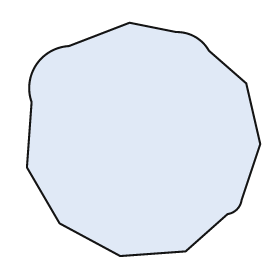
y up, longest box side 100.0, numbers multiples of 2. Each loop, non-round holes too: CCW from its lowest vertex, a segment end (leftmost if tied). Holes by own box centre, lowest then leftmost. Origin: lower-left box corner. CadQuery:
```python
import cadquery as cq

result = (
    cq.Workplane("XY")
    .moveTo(40.0, 0.0)
    .lineTo(68.0, 2.0)
    .lineTo(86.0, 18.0)
    .threePointArc((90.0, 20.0), (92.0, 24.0))
    .lineTo(100.0, 48.0)
    .lineTo(94.0, 74.0)
    .lineTo(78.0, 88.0)
    .threePointArc((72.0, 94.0), (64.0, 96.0))
    .lineTo(44.0, 100.0)
    .lineTo(18.0, 90.0)
    .threePointArc((4.0, 82.0), (2.0, 66.0))
    .lineTo(0.0, 38.0)
    .lineTo(14.0, 14.0)
    .close()
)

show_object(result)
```